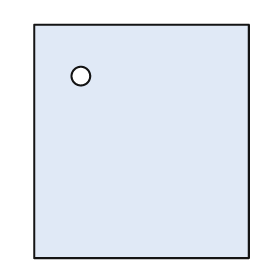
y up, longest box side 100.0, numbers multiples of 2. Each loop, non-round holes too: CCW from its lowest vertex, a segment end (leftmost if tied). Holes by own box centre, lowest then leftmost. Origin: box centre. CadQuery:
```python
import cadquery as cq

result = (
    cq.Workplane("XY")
    .moveTo(-46.0, -50.0)
    .lineTo(46.0, -50.0)
    .lineTo(46.0, 50.0)
    .lineTo(-46.0, 50.0)
    .close()
    .moveTo(-26.0, 28.0)
    .circle(4.0)
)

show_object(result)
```